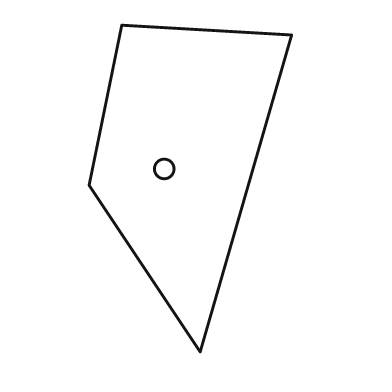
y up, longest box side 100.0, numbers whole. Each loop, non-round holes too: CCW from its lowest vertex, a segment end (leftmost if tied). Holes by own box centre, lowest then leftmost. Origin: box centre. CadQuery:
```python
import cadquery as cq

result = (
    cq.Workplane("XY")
    .moveTo(3.0, -50.0)
    .lineTo(31.0, 47.0)
    .lineTo(-21.0, 50.0)
    .lineTo(-31.0, 1.0)
    .close()
    .moveTo(-8.0, 6.0)
    .circle(3.0)
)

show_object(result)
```